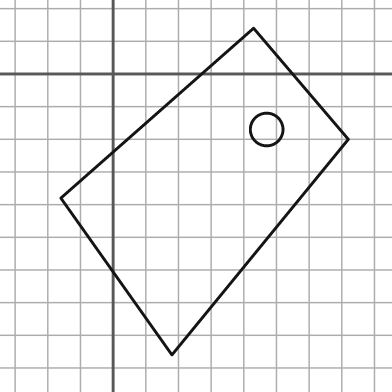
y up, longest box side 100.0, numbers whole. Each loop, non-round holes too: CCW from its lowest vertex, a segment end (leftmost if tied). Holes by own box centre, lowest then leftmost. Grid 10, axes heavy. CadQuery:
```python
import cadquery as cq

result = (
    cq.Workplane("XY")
    .moveTo(18.0, -86.0)
    .lineTo(72.0, -20.0)
    .lineTo(43.0, 14.0)
    .lineTo(-16.0, -38.0)
    .close()
    .moveTo(47.0, -17.0)
    .circle(5.0)
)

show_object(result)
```